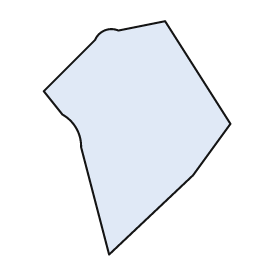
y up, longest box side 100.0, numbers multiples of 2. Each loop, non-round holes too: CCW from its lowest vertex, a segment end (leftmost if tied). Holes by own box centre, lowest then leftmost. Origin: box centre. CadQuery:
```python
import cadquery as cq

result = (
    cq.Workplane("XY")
    .moveTo(-12.0, -50.0)
    .lineTo(24.0, -16.0)
    .lineTo(40.0, 6.0)
    .lineTo(12.0, 50.0)
    .lineTo(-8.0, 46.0)
    .threePointArc((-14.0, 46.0), (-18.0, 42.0))
    .lineTo(-40.0, 20.0)
    .lineTo(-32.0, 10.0)
    .threePointArc((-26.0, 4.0), (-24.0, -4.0))
    .close()
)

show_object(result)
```